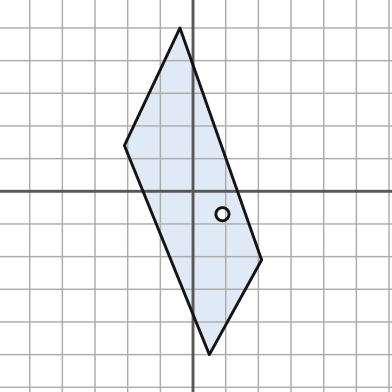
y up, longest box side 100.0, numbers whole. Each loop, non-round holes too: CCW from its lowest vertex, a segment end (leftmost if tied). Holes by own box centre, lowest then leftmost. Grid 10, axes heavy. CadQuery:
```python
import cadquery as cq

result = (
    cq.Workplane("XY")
    .moveTo(5.0, -50.0)
    .lineTo(21.0, -21.0)
    .lineTo(-4.0, 50.0)
    .lineTo(-21.0, 14.0)
    .close()
    .moveTo(9.0, -7.0)
    .circle(2.0)
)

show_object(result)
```